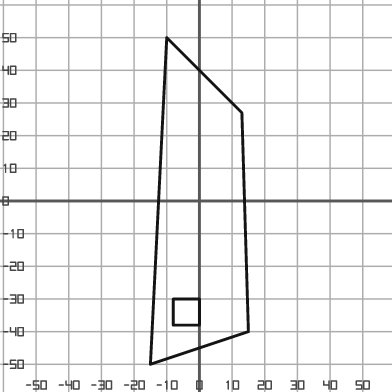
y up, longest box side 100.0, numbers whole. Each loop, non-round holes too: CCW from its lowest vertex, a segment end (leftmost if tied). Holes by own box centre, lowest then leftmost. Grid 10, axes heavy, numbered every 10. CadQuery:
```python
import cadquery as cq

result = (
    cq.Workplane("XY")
    .moveTo(-15.0, -50.0)
    .lineTo(15.0, -40.0)
    .lineTo(13.0, 27.0)
    .lineTo(-10.0, 50.0)
    .close()
    .moveTo(-8.0, -38.0)
    .lineTo(0.0, -38.0)
    .lineTo(0.0, -30.0)
    .lineTo(-8.0, -30.0)
    .close()
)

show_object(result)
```